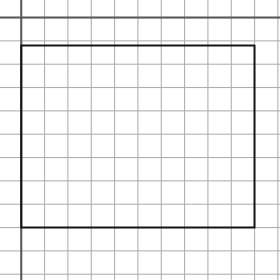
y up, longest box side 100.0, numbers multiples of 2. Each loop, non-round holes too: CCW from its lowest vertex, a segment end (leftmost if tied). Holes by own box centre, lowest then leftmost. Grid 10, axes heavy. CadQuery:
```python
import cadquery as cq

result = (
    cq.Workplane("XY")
    .moveTo(0.0, -90.0)
    .lineTo(100.0, -90.0)
    .lineTo(100.0, -12.0)
    .lineTo(0.0, -12.0)
    .close()
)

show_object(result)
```